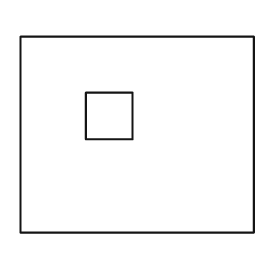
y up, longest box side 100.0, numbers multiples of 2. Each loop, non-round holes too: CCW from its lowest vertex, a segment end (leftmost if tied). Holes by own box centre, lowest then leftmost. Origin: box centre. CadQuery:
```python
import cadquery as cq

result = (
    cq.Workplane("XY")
    .moveTo(-50.0, -42.0)
    .lineTo(50.0, -42.0)
    .lineTo(50.0, 42.0)
    .lineTo(-50.0, 42.0)
    .close()
    .moveTo(-22.0, -2.0)
    .lineTo(-2.0, -2.0)
    .lineTo(-2.0, 18.0)
    .lineTo(-22.0, 18.0)
    .close()
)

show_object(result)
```